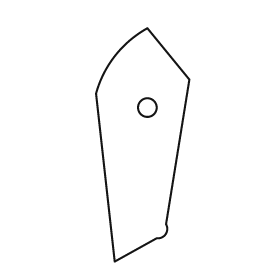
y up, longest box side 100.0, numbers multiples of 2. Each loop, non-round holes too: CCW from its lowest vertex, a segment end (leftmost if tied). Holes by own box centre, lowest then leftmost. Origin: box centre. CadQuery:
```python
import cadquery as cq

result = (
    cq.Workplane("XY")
    .moveTo(-12.0, -50.0)
    .lineTo(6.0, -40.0)
    .threePointArc((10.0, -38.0), (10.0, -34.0))
    .lineTo(20.0, 28.0)
    .lineTo(2.0, 50.0)
    .threePointArc((-12.0, 38.0), (-20.0, 22.0))
    .close()
    .moveTo(2.0, 16.0)
    .circle(4.0)
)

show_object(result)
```